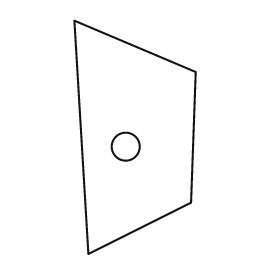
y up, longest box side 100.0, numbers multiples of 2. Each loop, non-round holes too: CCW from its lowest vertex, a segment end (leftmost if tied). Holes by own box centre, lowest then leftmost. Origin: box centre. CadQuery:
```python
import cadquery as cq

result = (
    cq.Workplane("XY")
    .moveTo(-20.0, -50.0)
    .lineTo(24.0, -28.0)
    .lineTo(26.0, 28.0)
    .lineTo(-26.0, 50.0)
    .close()
    .moveTo(-4.0, -4.0)
    .circle(6.0)
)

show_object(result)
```